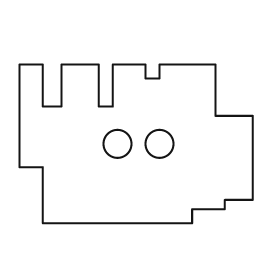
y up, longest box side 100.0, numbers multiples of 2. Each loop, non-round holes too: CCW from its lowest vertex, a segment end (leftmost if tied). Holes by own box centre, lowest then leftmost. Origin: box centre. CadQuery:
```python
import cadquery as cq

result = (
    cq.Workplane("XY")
    .moveTo(-40.0, -34.0)
    .lineTo(24.0, -34.0)
    .lineTo(24.0, -28.0)
    .lineTo(38.0, -28.0)
    .lineTo(38.0, -24.0)
    .lineTo(50.0, -24.0)
    .lineTo(50.0, 12.0)
    .lineTo(34.0, 12.0)
    .lineTo(34.0, 34.0)
    .lineTo(10.0, 34.0)
    .lineTo(10.0, 28.0)
    .lineTo(4.0, 28.0)
    .lineTo(4.0, 34.0)
    .lineTo(-10.0, 34.0)
    .lineTo(-10.0, 16.0)
    .lineTo(-16.0, 16.0)
    .lineTo(-16.0, 34.0)
    .lineTo(-32.0, 34.0)
    .lineTo(-32.0, 16.0)
    .lineTo(-40.0, 16.0)
    .lineTo(-40.0, 34.0)
    .lineTo(-50.0, 34.0)
    .lineTo(-50.0, -10.0)
    .lineTo(-40.0, -10.0)
    .close()
    .moveTo(-8.0, 0.0)
    .circle(6.0)
    .moveTo(10.0, 0.0)
    .circle(6.0)
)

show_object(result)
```